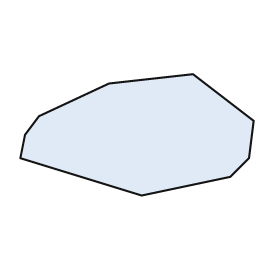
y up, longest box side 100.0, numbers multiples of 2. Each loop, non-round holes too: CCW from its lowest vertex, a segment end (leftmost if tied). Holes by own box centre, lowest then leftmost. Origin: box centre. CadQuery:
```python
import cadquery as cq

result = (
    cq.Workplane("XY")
    .moveTo(2.0, -26.0)
    .lineTo(40.0, -18.0)
    .lineTo(48.0, -10.0)
    .lineTo(50.0, 6.0)
    .lineTo(24.0, 26.0)
    .lineTo(-12.0, 22.0)
    .lineTo(-42.0, 8.0)
    .lineTo(-48.0, 0.0)
    .lineTo(-50.0, -10.0)
    .close()
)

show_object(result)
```